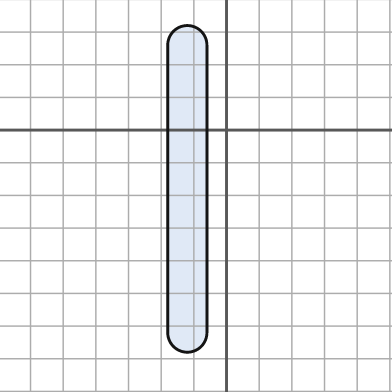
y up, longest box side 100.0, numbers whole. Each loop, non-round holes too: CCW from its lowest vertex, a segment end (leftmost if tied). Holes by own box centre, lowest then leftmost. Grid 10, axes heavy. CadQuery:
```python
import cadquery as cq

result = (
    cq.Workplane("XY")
    .moveTo(-18.0, -62.0)
    .threePointArc((-12.0, -68.0), (-6.0, -62.0))
    .lineTo(-6.0, 26.0)
    .threePointArc((-12.0, 32.0), (-18.0, 26.0))
    .close()
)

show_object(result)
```